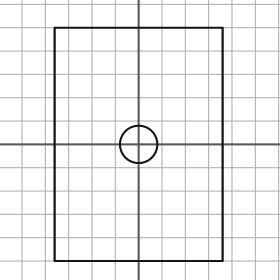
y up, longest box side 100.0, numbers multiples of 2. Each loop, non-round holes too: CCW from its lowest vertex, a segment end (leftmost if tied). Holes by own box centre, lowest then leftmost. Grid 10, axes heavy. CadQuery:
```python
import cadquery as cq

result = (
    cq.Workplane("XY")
    .moveTo(-36.0, -50.0)
    .lineTo(36.0, -50.0)
    .lineTo(36.0, 50.0)
    .lineTo(-36.0, 50.0)
    .close()
    .moveTo(0.0, 0.0)
    .circle(8.0)
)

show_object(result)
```